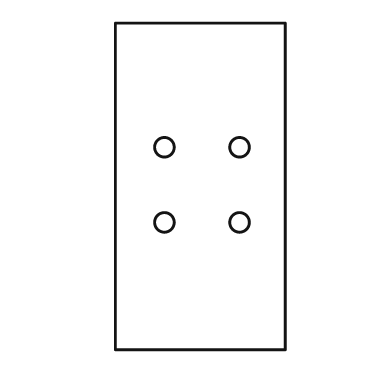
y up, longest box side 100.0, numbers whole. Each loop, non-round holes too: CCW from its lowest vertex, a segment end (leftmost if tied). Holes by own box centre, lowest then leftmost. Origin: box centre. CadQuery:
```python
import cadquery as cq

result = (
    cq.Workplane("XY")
    .moveTo(-26.0, -50.0)
    .lineTo(26.0, -50.0)
    .lineTo(26.0, 50.0)
    .lineTo(-26.0, 50.0)
    .close()
    .moveTo(-11.0, -11.0)
    .circle(3.0)
    .moveTo(12.0, -11.0)
    .circle(3.0)
    .moveTo(-11.0, 12.0)
    .circle(3.0)
    .moveTo(12.0, 12.0)
    .circle(3.0)
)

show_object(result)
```